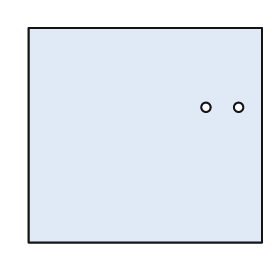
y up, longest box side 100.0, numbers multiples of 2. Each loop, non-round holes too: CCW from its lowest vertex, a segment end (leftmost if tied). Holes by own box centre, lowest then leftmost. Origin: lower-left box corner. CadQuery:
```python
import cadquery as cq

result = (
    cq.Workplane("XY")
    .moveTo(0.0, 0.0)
    .lineTo(100.0, 0.0)
    .lineTo(100.0, 92.0)
    .lineTo(0.0, 92.0)
    .close()
    .moveTo(76.0, 58.0)
    .circle(2.0)
    .moveTo(90.0, 58.0)
    .circle(2.0)
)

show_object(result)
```